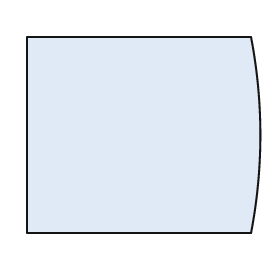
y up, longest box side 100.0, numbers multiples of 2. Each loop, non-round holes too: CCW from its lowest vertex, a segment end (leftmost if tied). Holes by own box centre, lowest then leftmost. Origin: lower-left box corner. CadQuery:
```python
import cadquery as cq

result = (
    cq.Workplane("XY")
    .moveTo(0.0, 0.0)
    .lineTo(96.0, 0.0)
    .threePointArc((100.0, 42.0), (96.0, 84.0))
    .lineTo(0.0, 84.0)
    .close()
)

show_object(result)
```